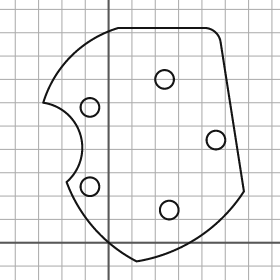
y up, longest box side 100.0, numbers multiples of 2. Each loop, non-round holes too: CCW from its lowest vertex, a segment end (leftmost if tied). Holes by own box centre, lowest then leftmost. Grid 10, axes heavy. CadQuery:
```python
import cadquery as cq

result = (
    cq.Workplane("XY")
    .moveTo(12.0, -8.0)
    .threePointArc((38.0, 2.0), (58.0, 22.0))
    .lineTo(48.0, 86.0)
    .threePointArc((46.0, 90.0), (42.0, 92.0))
    .lineTo(4.0, 92.0)
    .threePointArc((-16.0, 80.0), (-28.0, 60.0))
    .threePointArc((-12.0, 46.0), (-18.0, 26.0))
    .threePointArc((-6.0, 6.0), (12.0, -8.0))
    .close()
    .moveTo(26.0, 14.0)
    .circle(4.0)
    .moveTo(-8.0, 24.0)
    .circle(4.0)
    .moveTo(46.0, 44.0)
    .circle(4.0)
    .moveTo(-8.0, 58.0)
    .circle(4.0)
    .moveTo(24.0, 70.0)
    .circle(4.0)
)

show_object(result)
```